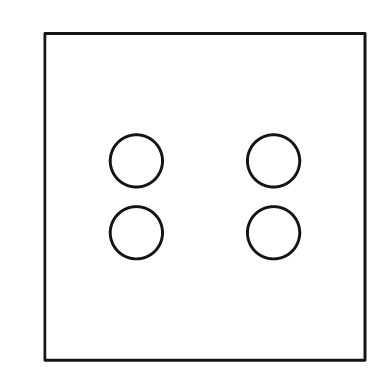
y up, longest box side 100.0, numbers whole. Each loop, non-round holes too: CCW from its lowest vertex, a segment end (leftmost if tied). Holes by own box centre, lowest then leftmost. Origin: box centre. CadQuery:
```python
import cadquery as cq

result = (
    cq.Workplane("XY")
    .moveTo(-49.0, -50.0)
    .lineTo(49.0, -50.0)
    .lineTo(49.0, 50.0)
    .lineTo(-49.0, 50.0)
    .close()
    .moveTo(-21.0, -11.0)
    .circle(8.0)
    .moveTo(21.0, -11.0)
    .circle(8.0)
    .moveTo(-21.0, 11.0)
    .circle(8.0)
    .moveTo(21.0, 11.0)
    .circle(8.0)
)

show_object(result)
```